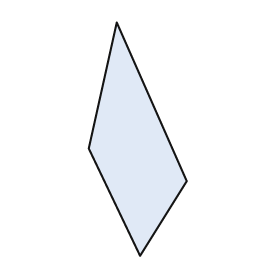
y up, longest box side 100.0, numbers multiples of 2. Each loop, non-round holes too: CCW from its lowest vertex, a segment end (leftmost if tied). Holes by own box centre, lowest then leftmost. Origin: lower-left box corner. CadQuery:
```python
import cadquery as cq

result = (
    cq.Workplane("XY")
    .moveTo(22.0, 0.0)
    .lineTo(42.0, 32.0)
    .lineTo(12.0, 100.0)
    .lineTo(0.0, 46.0)
    .close()
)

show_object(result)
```